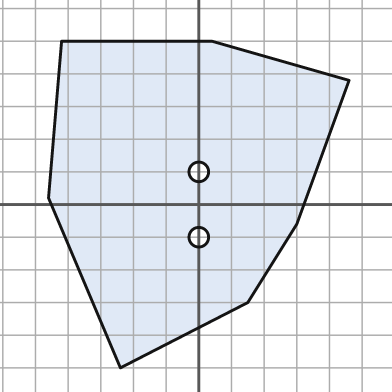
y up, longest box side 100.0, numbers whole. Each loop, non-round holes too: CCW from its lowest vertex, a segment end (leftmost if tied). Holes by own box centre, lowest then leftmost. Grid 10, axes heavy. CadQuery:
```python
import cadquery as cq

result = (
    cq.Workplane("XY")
    .moveTo(-24.0, -50.0)
    .lineTo(15.0, -30.0)
    .lineTo(30.0, -6.0)
    .lineTo(46.0, 38.0)
    .lineTo(4.0, 50.0)
    .lineTo(-42.0, 50.0)
    .lineTo(-46.0, 2.0)
    .close()
    .moveTo(0.0, -10.0)
    .circle(3.0)
    .moveTo(0.0, 10.0)
    .circle(3.0)
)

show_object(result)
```